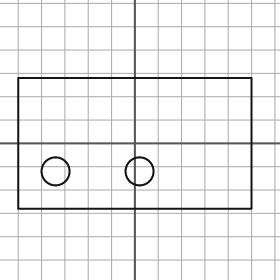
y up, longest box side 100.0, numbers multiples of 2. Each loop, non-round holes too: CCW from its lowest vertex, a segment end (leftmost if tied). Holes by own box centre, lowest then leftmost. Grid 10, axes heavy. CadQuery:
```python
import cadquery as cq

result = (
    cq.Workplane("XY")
    .moveTo(-50.0, -28.0)
    .lineTo(50.0, -28.0)
    .lineTo(50.0, 28.0)
    .lineTo(-50.0, 28.0)
    .close()
    .moveTo(-34.0, -12.0)
    .circle(6.0)
    .moveTo(2.0, -12.0)
    .circle(6.0)
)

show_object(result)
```